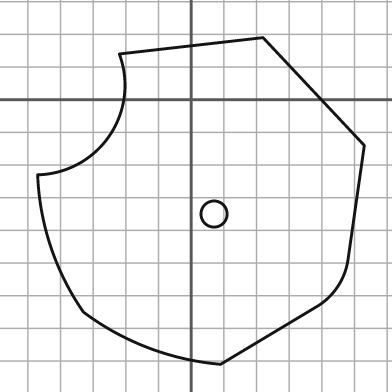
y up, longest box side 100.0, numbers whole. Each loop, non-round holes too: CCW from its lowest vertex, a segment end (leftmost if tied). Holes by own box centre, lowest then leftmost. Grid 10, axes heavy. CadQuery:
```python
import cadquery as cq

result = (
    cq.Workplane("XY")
    .moveTo(9.0, -81.0)
    .lineTo(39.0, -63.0)
    .threePointArc((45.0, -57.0), (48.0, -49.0))
    .lineTo(53.0, -14.0)
    .lineTo(22.0, 19.0)
    .lineTo(-22.0, 14.0)
    .threePointArc((-25.0, -11.0), (-47.0, -23.0))
    .threePointArc((-43.0, -45.0), (-33.0, -65.0))
    .threePointArc((-13.0, -76.0), (9.0, -81.0))
    .close()
    .moveTo(7.0, -35.0)
    .circle(4.0)
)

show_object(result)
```